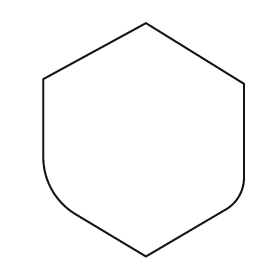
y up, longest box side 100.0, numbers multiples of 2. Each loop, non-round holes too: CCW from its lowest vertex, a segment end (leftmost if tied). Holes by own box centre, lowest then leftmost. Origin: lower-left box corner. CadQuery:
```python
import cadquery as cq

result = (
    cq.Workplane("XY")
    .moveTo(44.0, 0.0)
    .lineTo(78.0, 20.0)
    .threePointArc((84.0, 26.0), (86.0, 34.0))
    .lineTo(86.0, 74.0)
    .lineTo(44.0, 100.0)
    .lineTo(0.0, 76.0)
    .lineTo(0.0, 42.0)
    .threePointArc((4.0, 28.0), (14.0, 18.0))
    .close()
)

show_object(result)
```